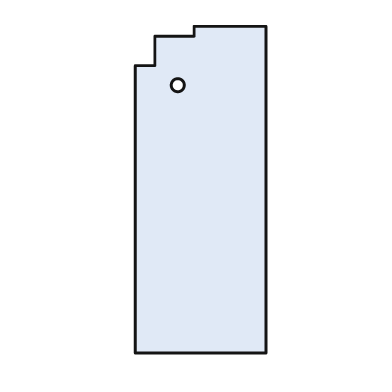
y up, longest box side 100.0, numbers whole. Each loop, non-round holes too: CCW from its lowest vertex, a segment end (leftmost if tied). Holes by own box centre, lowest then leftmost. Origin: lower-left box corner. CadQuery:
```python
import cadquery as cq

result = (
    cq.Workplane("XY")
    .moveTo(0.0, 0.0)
    .lineTo(40.0, 0.0)
    .lineTo(40.0, 100.0)
    .lineTo(18.0, 100.0)
    .lineTo(18.0, 97.0)
    .lineTo(6.0, 97.0)
    .lineTo(6.0, 88.0)
    .lineTo(0.0, 88.0)
    .close()
    .moveTo(13.0, 82.0)
    .circle(2.0)
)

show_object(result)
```